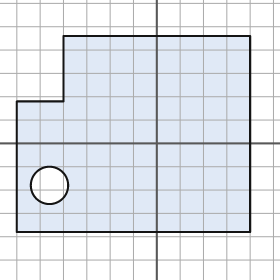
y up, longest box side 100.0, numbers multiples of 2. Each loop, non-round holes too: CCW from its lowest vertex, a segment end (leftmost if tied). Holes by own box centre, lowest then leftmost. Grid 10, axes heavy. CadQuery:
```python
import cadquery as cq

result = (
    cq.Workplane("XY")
    .moveTo(-60.0, -38.0)
    .lineTo(40.0, -38.0)
    .lineTo(40.0, 46.0)
    .lineTo(-40.0, 46.0)
    .lineTo(-40.0, 18.0)
    .lineTo(-60.0, 18.0)
    .close()
    .moveTo(-46.0, -18.0)
    .circle(8.0)
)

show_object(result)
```